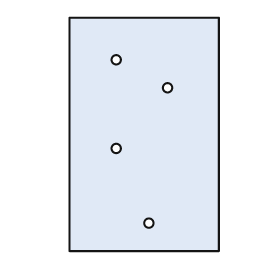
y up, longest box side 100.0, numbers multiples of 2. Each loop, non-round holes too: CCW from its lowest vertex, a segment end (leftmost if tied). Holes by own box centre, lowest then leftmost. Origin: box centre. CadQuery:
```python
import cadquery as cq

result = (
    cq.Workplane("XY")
    .moveTo(-32.0, -50.0)
    .lineTo(32.0, -50.0)
    .lineTo(32.0, 50.0)
    .lineTo(-32.0, 50.0)
    .close()
    .moveTo(2.0, -38.0)
    .circle(2.0)
    .moveTo(-12.0, -6.0)
    .circle(2.0)
    .moveTo(10.0, 20.0)
    .circle(2.0)
    .moveTo(-12.0, 32.0)
    .circle(2.0)
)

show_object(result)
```